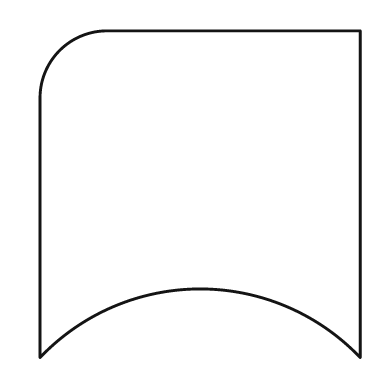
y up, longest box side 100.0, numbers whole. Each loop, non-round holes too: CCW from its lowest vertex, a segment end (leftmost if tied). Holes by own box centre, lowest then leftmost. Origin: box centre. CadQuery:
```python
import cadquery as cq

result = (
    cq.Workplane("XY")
    .moveTo(-49.0, -50.0)
    .threePointArc((0.0, -29.0), (49.0, -50.0))
    .lineTo(49.0, 50.0)
    .lineTo(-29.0, 50.0)
    .threePointArc((-43.0, 44.0), (-49.0, 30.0))
    .close()
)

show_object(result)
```